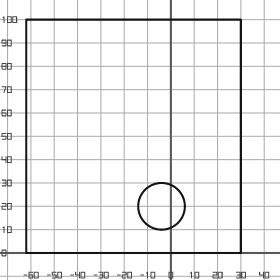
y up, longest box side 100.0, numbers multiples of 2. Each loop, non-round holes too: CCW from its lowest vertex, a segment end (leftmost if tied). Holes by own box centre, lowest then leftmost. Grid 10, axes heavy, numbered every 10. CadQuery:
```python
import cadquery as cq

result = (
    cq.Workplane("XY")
    .moveTo(-62.0, 0.0)
    .lineTo(30.0, 0.0)
    .lineTo(30.0, 100.0)
    .lineTo(-62.0, 100.0)
    .close()
    .moveTo(-4.0, 20.0)
    .circle(10.0)
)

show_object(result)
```